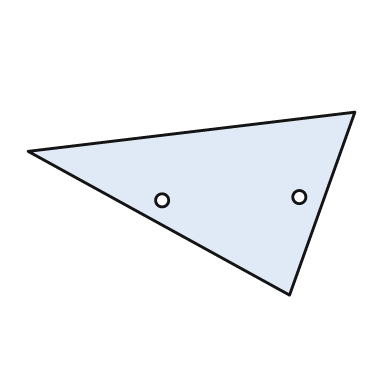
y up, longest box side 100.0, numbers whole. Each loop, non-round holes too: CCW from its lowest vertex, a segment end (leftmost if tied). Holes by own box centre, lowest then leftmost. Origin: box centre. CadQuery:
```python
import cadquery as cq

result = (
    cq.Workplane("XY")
    .moveTo(30.0, -28.0)
    .lineTo(50.0, 28.0)
    .lineTo(-50.0, 16.0)
    .close()
    .moveTo(-9.0, 1.0)
    .circle(2.0)
    .moveTo(33.0, 2.0)
    .circle(2.0)
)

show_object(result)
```